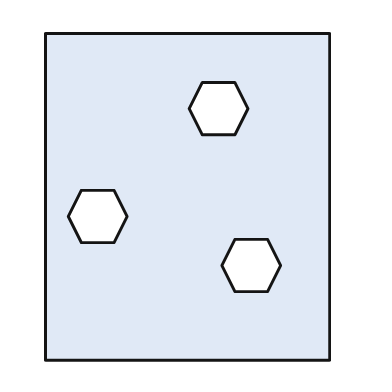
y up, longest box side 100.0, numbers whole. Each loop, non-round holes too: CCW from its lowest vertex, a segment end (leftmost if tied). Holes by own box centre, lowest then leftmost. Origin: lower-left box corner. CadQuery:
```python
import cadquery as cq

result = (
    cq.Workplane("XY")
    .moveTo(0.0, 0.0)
    .lineTo(87.0, 0.0)
    .lineTo(87.0, 100.0)
    .lineTo(0.0, 100.0)
    .close()
    .moveTo(58.0, 21.0)
    .lineTo(68.0, 21.0)
    .lineTo(72.0, 29.0)
    .lineTo(68.0, 37.0)
    .lineTo(58.0, 37.0)
    .lineTo(54.0, 29.0)
    .close()
    .moveTo(11.0, 36.0)
    .lineTo(21.0, 36.0)
    .lineTo(25.0, 44.0)
    .lineTo(21.0, 52.0)
    .lineTo(11.0, 52.0)
    .lineTo(7.0, 44.0)
    .close()
    .moveTo(48.0, 69.0)
    .lineTo(58.0, 69.0)
    .lineTo(62.0, 77.0)
    .lineTo(58.0, 85.0)
    .lineTo(48.0, 85.0)
    .lineTo(44.0, 77.0)
    .close()
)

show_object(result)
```